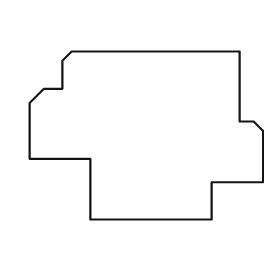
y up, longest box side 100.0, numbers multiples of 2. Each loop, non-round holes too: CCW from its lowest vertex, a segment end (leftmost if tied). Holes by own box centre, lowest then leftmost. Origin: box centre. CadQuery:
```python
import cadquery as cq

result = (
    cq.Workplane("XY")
    .moveTo(-24.0, -36.0)
    .lineTo(28.0, -36.0)
    .lineTo(28.0, -20.0)
    .lineTo(50.0, -20.0)
    .lineTo(50.0, 2.0)
    .lineTo(46.0, 6.0)
    .lineTo(40.0, 6.0)
    .lineTo(40.0, 36.0)
    .lineTo(-32.0, 36.0)
    .lineTo(-36.0, 32.0)
    .lineTo(-36.0, 20.0)
    .lineTo(-44.0, 20.0)
    .lineTo(-50.0, 14.0)
    .lineTo(-50.0, -10.0)
    .lineTo(-24.0, -10.0)
    .close()
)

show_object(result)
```